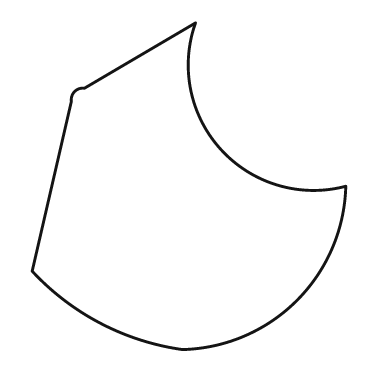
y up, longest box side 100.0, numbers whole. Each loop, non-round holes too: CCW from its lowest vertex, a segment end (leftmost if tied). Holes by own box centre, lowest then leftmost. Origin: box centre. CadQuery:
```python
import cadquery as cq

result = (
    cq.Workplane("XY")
    .moveTo(-2.0, -50.0)
    .threePointArc((33.0, -35.0), (48.0, 0.0))
    .threePointArc((10.0, 11.0), (2.0, 50.0))
    .lineTo(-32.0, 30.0)
    .threePointArc((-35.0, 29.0), (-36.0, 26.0))
    .lineTo(-48.0, -26.0)
    .threePointArc((-27.0, -42.0), (-2.0, -50.0))
    .close()
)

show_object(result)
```